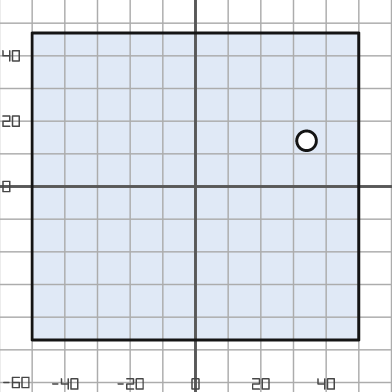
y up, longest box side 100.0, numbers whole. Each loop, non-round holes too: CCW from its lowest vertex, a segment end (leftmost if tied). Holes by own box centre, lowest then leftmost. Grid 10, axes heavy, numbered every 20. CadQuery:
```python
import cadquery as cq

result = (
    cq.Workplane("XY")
    .moveTo(-50.0, -47.0)
    .lineTo(50.0, -47.0)
    .lineTo(50.0, 47.0)
    .lineTo(-50.0, 47.0)
    .close()
    .moveTo(34.0, 14.0)
    .circle(3.0)
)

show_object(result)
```